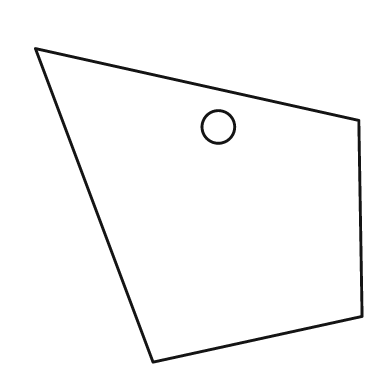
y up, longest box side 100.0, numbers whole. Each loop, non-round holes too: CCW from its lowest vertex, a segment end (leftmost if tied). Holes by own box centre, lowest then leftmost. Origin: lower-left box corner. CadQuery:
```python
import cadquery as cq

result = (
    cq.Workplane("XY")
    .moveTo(36.0, 0.0)
    .lineTo(100.0, 14.0)
    .lineTo(99.0, 74.0)
    .lineTo(0.0, 96.0)
    .close()
    .moveTo(56.0, 72.0)
    .circle(5.0)
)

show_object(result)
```